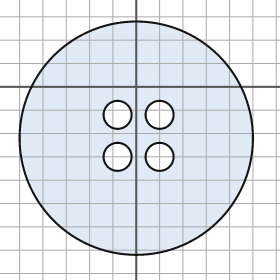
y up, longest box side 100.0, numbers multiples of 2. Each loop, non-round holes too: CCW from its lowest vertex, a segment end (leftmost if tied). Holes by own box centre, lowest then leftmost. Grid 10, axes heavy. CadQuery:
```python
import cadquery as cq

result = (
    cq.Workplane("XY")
    .moveTo(0.0, -22.0)
    .circle(50.0)
    .moveTo(-8.0, -30.0)
    .circle(6.0)
    .moveTo(10.0, -30.0)
    .circle(6.0)
    .moveTo(-8.0, -12.0)
    .circle(6.0)
    .moveTo(10.0, -12.0)
    .circle(6.0)
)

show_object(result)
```